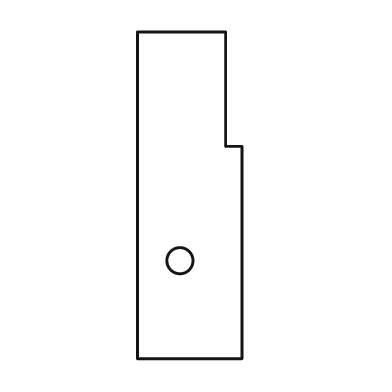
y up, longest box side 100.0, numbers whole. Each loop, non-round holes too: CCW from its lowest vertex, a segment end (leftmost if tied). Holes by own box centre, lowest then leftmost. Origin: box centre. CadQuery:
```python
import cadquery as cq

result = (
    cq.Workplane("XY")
    .moveTo(-16.0, -50.0)
    .lineTo(16.0, -50.0)
    .lineTo(16.0, 15.0)
    .lineTo(11.0, 15.0)
    .lineTo(11.0, 50.0)
    .lineTo(-16.0, 50.0)
    .close()
    .moveTo(-3.0, -20.0)
    .circle(4.0)
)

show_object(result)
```